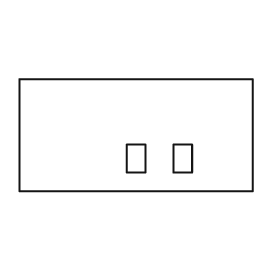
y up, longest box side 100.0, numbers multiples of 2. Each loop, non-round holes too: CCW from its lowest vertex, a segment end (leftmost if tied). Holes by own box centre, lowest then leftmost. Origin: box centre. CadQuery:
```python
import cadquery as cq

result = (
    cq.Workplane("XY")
    .moveTo(-50.0, -24.0)
    .lineTo(50.0, -24.0)
    .lineTo(50.0, 24.0)
    .lineTo(-50.0, 24.0)
    .close()
    .moveTo(-4.0, -16.0)
    .lineTo(4.0, -16.0)
    .lineTo(4.0, -4.0)
    .lineTo(-4.0, -4.0)
    .close()
    .moveTo(16.0, -16.0)
    .lineTo(24.0, -16.0)
    .lineTo(24.0, -4.0)
    .lineTo(16.0, -4.0)
    .close()
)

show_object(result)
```